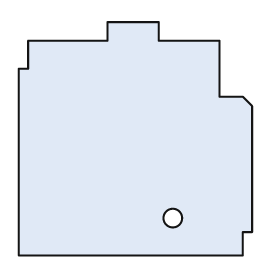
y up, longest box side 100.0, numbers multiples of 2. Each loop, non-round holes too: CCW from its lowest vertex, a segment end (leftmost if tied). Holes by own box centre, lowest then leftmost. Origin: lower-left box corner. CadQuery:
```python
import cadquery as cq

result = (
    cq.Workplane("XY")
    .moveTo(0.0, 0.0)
    .lineTo(96.0, 0.0)
    .lineTo(96.0, 10.0)
    .lineTo(100.0, 10.0)
    .lineTo(100.0, 64.0)
    .lineTo(96.0, 68.0)
    .lineTo(86.0, 68.0)
    .lineTo(86.0, 92.0)
    .lineTo(60.0, 92.0)
    .lineTo(60.0, 100.0)
    .lineTo(38.0, 100.0)
    .lineTo(38.0, 92.0)
    .lineTo(4.0, 92.0)
    .lineTo(4.0, 80.0)
    .lineTo(0.0, 80.0)
    .close()
    .moveTo(66.0, 16.0)
    .circle(4.0)
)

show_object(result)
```